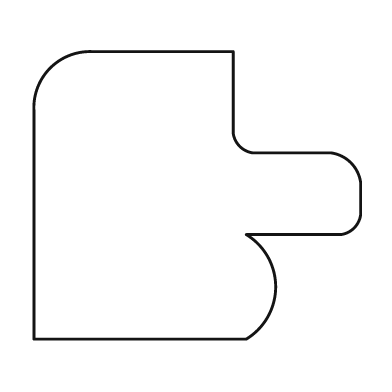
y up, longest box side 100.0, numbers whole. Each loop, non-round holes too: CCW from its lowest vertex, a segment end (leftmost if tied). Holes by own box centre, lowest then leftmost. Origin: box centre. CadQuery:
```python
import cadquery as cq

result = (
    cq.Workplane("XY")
    .moveTo(-50.0, -44.0)
    .lineTo(15.0, -44.0)
    .threePointArc((24.0, -28.0), (15.0, -12.0))
    .lineTo(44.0, -12.0)
    .threePointArc((48.0, -10.0), (50.0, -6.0))
    .lineTo(50.0, 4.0)
    .threePointArc((47.0, 10.0), (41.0, 13.0))
    .lineTo(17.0, 13.0)
    .threePointArc((13.0, 15.0), (11.0, 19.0))
    .lineTo(11.0, 44.0)
    .lineTo(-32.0, 44.0)
    .threePointArc((-45.0, 39.0), (-50.0, 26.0))
    .close()
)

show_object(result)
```